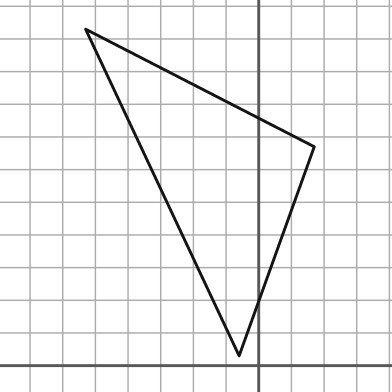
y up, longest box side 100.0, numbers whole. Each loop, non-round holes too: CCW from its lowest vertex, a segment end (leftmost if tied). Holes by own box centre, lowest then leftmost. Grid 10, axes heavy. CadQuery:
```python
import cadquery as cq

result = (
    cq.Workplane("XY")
    .moveTo(-6.0, 3.0)
    .lineTo(17.0, 67.0)
    .lineTo(-53.0, 103.0)
    .close()
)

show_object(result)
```